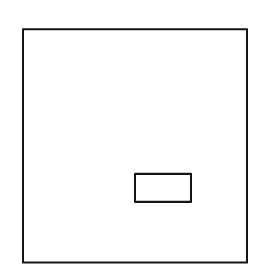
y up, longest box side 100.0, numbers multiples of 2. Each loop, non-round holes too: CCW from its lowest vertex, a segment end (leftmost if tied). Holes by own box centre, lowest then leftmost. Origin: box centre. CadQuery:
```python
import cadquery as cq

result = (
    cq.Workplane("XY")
    .moveTo(-48.0, -50.0)
    .lineTo(48.0, -50.0)
    .lineTo(48.0, 50.0)
    .lineTo(-48.0, 50.0)
    .close()
    .moveTo(0.0, -24.0)
    .lineTo(24.0, -24.0)
    .lineTo(24.0, -12.0)
    .lineTo(0.0, -12.0)
    .close()
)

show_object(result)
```